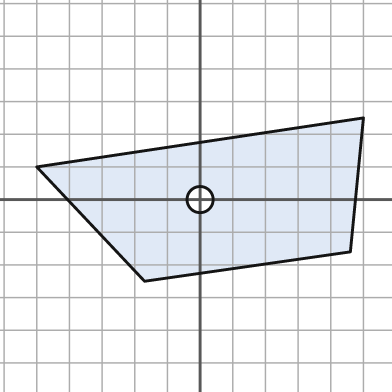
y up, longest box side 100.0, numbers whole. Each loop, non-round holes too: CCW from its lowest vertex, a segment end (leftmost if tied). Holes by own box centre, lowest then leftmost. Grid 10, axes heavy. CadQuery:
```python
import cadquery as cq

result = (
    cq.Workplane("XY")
    .moveTo(-17.0, -25.0)
    .lineTo(46.0, -16.0)
    .lineTo(50.0, 25.0)
    .lineTo(-50.0, 10.0)
    .close()
    .moveTo(0.0, 0.0)
    .circle(4.0)
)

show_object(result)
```